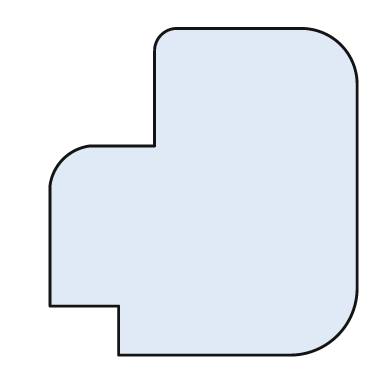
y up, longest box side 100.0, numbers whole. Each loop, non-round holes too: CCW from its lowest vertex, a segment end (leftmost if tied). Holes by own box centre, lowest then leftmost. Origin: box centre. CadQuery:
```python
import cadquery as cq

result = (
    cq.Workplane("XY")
    .moveTo(-26.0, -50.0)
    .lineTo(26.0, -50.0)
    .threePointArc((41.0, -44.0), (47.0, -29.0))
    .lineTo(47.0, 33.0)
    .threePointArc((42.0, 45.0), (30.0, 50.0))
    .lineTo(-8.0, 50.0)
    .threePointArc((-13.0, 48.0), (-15.0, 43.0))
    .lineTo(-15.0, 14.0)
    .lineTo(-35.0, 14.0)
    .threePointArc((-43.0, 10.0), (-47.0, 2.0))
    .lineTo(-47.0, -35.0)
    .lineTo(-26.0, -35.0)
    .close()
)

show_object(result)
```